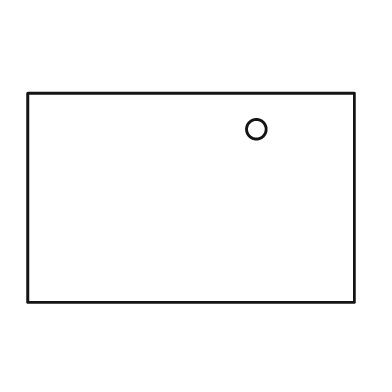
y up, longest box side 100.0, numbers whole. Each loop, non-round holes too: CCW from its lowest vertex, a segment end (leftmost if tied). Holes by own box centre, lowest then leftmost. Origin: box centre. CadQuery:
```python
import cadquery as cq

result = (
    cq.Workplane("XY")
    .moveTo(-50.0, -32.0)
    .lineTo(50.0, -32.0)
    .lineTo(50.0, 32.0)
    .lineTo(-50.0, 32.0)
    .close()
    .moveTo(20.0, 21.0)
    .circle(3.0)
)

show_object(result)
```